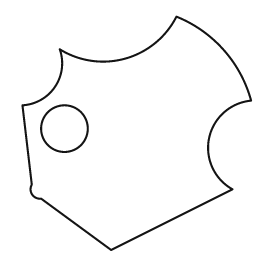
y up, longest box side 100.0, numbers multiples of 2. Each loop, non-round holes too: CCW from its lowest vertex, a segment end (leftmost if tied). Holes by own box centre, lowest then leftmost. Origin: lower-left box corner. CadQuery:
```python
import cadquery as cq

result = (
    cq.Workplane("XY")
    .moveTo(38.0, 0.0)
    .lineTo(90.0, 26.0)
    .threePointArc((80.0, 48.0), (98.0, 64.0))
    .threePointArc((86.0, 86.0), (66.0, 100.0))
    .threePointArc((44.0, 82.0), (16.0, 86.0))
    .threePointArc((14.0, 70.0), (0.0, 62.0))
    .lineTo(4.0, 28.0)
    .threePointArc((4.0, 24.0), (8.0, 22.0))
    .close()
    .moveTo(18.0, 52.0)
    .circle(10.0)
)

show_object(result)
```